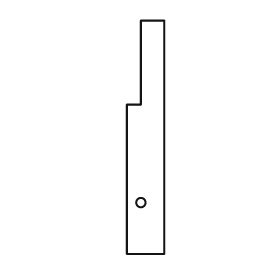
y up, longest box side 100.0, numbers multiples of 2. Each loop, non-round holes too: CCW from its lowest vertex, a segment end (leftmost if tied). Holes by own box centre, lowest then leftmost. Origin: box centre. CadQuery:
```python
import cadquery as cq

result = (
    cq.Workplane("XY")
    .moveTo(-8.0, -50.0)
    .lineTo(8.0, -50.0)
    .lineTo(8.0, 50.0)
    .lineTo(-2.0, 50.0)
    .lineTo(-2.0, 14.0)
    .lineTo(-8.0, 14.0)
    .close()
    .moveTo(-2.0, -28.0)
    .circle(2.0)
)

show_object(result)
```